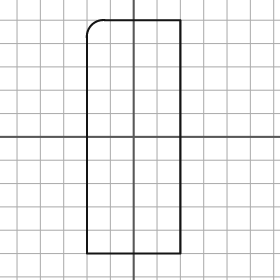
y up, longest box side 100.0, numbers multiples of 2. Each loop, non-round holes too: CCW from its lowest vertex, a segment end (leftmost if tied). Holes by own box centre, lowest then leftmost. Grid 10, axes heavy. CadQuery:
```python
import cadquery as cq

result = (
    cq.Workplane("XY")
    .moveTo(-20.0, -50.0)
    .lineTo(20.0, -50.0)
    .lineTo(20.0, 50.0)
    .lineTo(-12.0, 50.0)
    .threePointArc((-18.0, 48.0), (-20.0, 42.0))
    .close()
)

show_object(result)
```